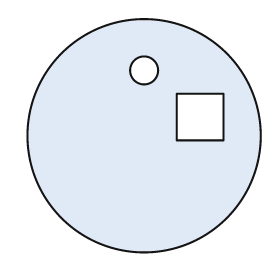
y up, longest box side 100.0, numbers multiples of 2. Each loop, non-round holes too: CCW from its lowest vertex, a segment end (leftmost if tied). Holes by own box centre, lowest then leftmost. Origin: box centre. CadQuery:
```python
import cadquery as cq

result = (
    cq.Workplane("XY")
    .moveTo(0.0, 0.0)
    .circle(50.0)
    .moveTo(14.0, -2.0)
    .lineTo(34.0, -2.0)
    .lineTo(34.0, 18.0)
    .lineTo(14.0, 18.0)
    .close()
    .moveTo(0.0, 28.0)
    .circle(6.0)
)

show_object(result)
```